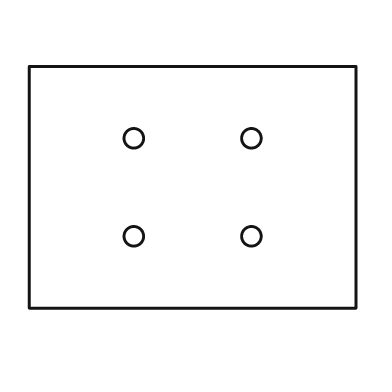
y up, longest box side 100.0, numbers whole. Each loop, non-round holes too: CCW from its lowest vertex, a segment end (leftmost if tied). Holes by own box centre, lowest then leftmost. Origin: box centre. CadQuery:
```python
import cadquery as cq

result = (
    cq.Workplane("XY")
    .moveTo(-50.0, -37.0)
    .lineTo(50.0, -37.0)
    .lineTo(50.0, 37.0)
    .lineTo(-50.0, 37.0)
    .close()
    .moveTo(-18.0, -15.0)
    .circle(3.0)
    .moveTo(18.0, -15.0)
    .circle(3.0)
    .moveTo(-18.0, 15.0)
    .circle(3.0)
    .moveTo(18.0, 15.0)
    .circle(3.0)
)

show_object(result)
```